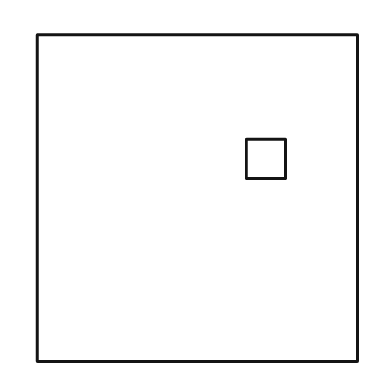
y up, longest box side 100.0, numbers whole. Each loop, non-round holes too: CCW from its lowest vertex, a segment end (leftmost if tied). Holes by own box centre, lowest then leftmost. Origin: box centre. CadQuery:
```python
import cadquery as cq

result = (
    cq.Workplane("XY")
    .moveTo(-49.0, -50.0)
    .lineTo(49.0, -50.0)
    .lineTo(49.0, 50.0)
    .lineTo(-49.0, 50.0)
    .close()
    .moveTo(15.0, 6.0)
    .lineTo(27.0, 6.0)
    .lineTo(27.0, 18.0)
    .lineTo(15.0, 18.0)
    .close()
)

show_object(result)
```